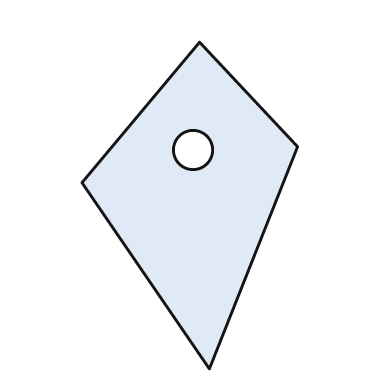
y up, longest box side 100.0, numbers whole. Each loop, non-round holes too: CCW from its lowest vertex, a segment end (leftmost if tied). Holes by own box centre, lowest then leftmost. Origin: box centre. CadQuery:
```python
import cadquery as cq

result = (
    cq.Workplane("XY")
    .moveTo(6.0, -50.0)
    .lineTo(33.0, 18.0)
    .lineTo(3.0, 50.0)
    .lineTo(-33.0, 7.0)
    .close()
    .moveTo(1.0, 17.0)
    .circle(6.0)
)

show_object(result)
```